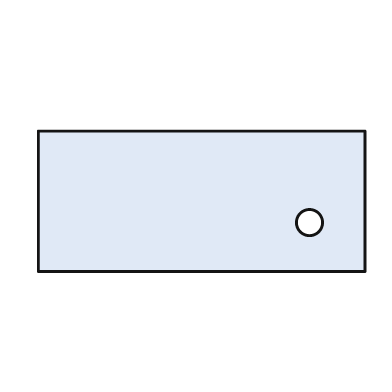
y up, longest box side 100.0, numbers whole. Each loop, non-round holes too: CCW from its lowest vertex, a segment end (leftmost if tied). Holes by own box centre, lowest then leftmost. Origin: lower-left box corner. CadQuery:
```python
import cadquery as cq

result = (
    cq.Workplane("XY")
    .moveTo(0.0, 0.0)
    .lineTo(100.0, 0.0)
    .lineTo(100.0, 43.0)
    .lineTo(0.0, 43.0)
    .close()
    .moveTo(83.0, 15.0)
    .circle(4.0)
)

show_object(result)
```